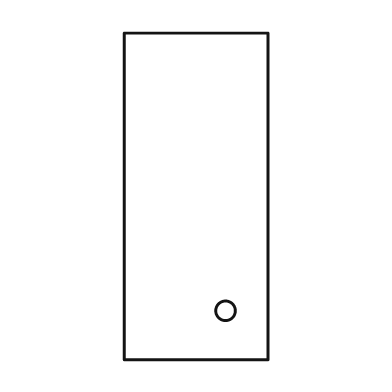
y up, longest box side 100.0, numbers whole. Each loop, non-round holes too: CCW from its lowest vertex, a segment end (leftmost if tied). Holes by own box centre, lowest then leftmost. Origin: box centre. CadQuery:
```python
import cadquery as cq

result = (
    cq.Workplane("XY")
    .moveTo(-22.0, -50.0)
    .lineTo(22.0, -50.0)
    .lineTo(22.0, 50.0)
    .lineTo(-22.0, 50.0)
    .close()
    .moveTo(9.0, -35.0)
    .circle(3.0)
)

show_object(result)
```